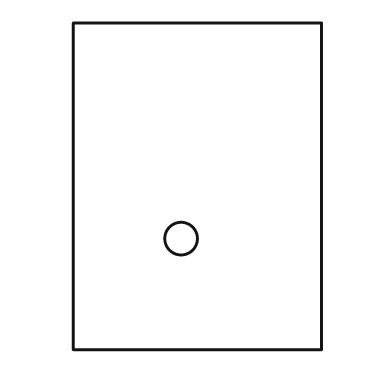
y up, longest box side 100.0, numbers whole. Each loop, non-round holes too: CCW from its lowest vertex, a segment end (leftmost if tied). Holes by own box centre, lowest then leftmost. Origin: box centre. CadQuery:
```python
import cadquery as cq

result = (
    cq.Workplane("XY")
    .moveTo(-38.0, -50.0)
    .lineTo(38.0, -50.0)
    .lineTo(38.0, 50.0)
    .lineTo(-38.0, 50.0)
    .close()
    .moveTo(-5.0, -16.0)
    .circle(5.0)
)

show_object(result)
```